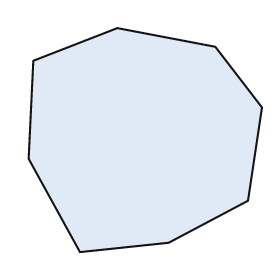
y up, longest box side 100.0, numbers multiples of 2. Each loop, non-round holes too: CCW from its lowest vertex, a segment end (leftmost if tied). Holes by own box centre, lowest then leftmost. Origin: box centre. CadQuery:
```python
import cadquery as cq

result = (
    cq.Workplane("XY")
    .moveTo(-28.0, -48.0)
    .lineTo(10.0, -44.0)
    .lineTo(44.0, -26.0)
    .lineTo(50.0, 14.0)
    .lineTo(30.0, 40.0)
    .lineTo(-12.0, 48.0)
    .lineTo(-48.0, 34.0)
    .lineTo(-50.0, -8.0)
    .close()
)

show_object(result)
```